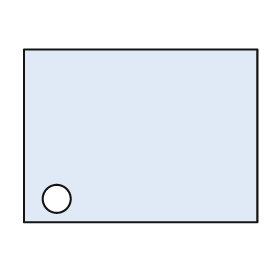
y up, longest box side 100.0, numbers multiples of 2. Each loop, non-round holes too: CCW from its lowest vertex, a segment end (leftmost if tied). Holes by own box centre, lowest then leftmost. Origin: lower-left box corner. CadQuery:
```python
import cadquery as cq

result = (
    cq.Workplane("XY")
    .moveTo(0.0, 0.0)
    .lineTo(100.0, 0.0)
    .lineTo(100.0, 74.0)
    .lineTo(0.0, 74.0)
    .close()
    .moveTo(14.0, 10.0)
    .circle(6.0)
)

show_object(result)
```